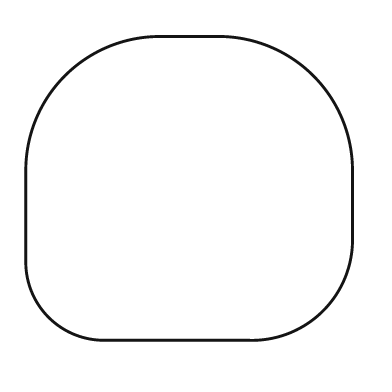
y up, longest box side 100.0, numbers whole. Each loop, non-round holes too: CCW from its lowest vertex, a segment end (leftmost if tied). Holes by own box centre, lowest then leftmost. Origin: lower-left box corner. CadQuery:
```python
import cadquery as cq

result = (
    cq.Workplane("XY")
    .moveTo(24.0, 0.0)
    .lineTo(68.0, 0.0)
    .threePointArc((91.0, 9.0), (100.0, 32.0))
    .lineTo(100.0, 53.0)
    .threePointArc((88.0, 81.0), (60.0, 93.0))
    .lineTo(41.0, 93.0)
    .threePointArc((12.0, 81.0), (0.0, 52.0))
    .lineTo(0.0, 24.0)
    .threePointArc((7.0, 7.0), (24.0, 0.0))
    .close()
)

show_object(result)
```